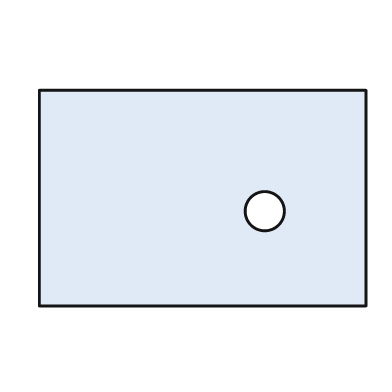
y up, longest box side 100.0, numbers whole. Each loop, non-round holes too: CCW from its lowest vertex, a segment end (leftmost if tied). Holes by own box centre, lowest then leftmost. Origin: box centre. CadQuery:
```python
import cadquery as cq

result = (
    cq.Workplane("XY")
    .moveTo(-50.0, -33.0)
    .lineTo(50.0, -33.0)
    .lineTo(50.0, 33.0)
    .lineTo(-50.0, 33.0)
    .close()
    .moveTo(19.0, -4.0)
    .circle(6.0)
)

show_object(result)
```